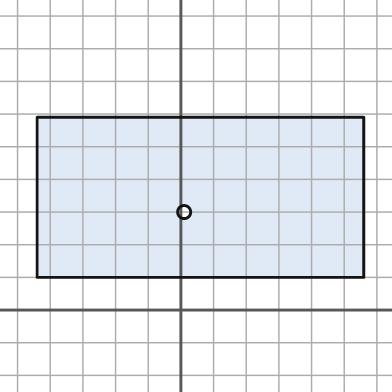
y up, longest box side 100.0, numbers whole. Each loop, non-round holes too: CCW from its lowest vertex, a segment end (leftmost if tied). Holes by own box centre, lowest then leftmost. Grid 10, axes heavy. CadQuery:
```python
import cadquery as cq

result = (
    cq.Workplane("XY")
    .moveTo(-44.0, 10.0)
    .lineTo(56.0, 10.0)
    .lineTo(56.0, 59.0)
    .lineTo(-44.0, 59.0)
    .close()
    .moveTo(1.0, 30.0)
    .circle(2.0)
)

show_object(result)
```